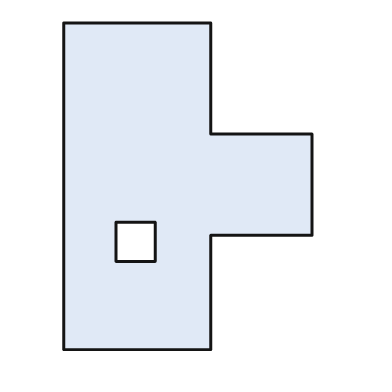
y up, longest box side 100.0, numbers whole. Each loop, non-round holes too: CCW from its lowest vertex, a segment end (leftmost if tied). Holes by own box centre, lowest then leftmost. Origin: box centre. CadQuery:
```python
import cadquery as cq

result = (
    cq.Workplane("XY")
    .moveTo(-38.0, -50.0)
    .lineTo(7.0, -50.0)
    .lineTo(7.0, -15.0)
    .lineTo(38.0, -15.0)
    .lineTo(38.0, 16.0)
    .lineTo(7.0, 16.0)
    .lineTo(7.0, 50.0)
    .lineTo(-38.0, 50.0)
    .close()
    .moveTo(-22.0, -23.0)
    .lineTo(-10.0, -23.0)
    .lineTo(-10.0, -11.0)
    .lineTo(-22.0, -11.0)
    .close()
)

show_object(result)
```